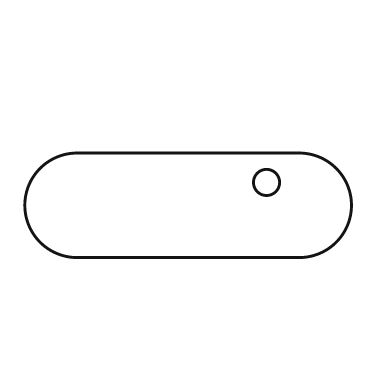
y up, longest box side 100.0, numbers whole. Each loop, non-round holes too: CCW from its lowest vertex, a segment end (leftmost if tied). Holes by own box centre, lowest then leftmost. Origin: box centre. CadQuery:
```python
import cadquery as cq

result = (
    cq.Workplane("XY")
    .moveTo(-34.0, -16.0)
    .lineTo(34.0, -16.0)
    .threePointArc((50.0, 0.0), (34.0, 16.0))
    .lineTo(-34.0, 16.0)
    .threePointArc((-50.0, 0.0), (-34.0, -16.0))
    .close()
    .moveTo(24.0, 7.0)
    .circle(4.0)
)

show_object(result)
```